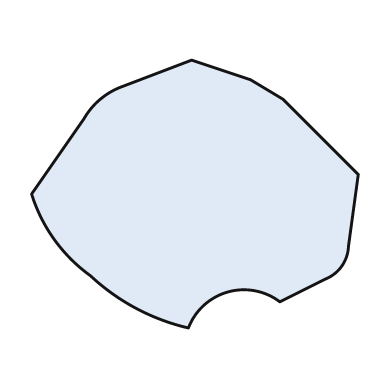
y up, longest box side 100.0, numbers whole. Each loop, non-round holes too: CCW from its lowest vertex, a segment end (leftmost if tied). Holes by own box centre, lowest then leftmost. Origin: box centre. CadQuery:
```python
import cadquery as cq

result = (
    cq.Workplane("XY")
    .moveTo(-2.0, -41.0)
    .threePointArc((10.0, -30.0), (26.0, -33.0))
    .lineTo(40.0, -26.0)
    .threePointArc((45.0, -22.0), (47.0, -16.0))
    .lineTo(50.0, 6.0)
    .lineTo(27.0, 29.0)
    .lineTo(17.0, 35.0)
    .lineTo(-1.0, 41.0)
    .lineTo(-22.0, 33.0)
    .threePointArc((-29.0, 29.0), (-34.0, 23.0))
    .lineTo(-50.0, 0.0)
    .threePointArc((-43.0, -14.0), (-32.0, -25.0))
    .threePointArc((-18.0, -35.0), (-2.0, -41.0))
    .close()
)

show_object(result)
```